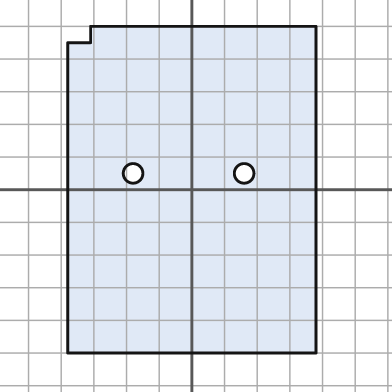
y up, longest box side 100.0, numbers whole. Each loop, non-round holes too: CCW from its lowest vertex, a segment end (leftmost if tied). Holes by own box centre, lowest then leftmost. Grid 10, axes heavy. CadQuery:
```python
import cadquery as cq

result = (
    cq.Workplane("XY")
    .moveTo(-38.0, -50.0)
    .lineTo(38.0, -50.0)
    .lineTo(38.0, 50.0)
    .lineTo(-31.0, 50.0)
    .lineTo(-31.0, 45.0)
    .lineTo(-38.0, 45.0)
    .close()
    .moveTo(-18.0, 5.0)
    .circle(3.0)
    .moveTo(16.0, 5.0)
    .circle(3.0)
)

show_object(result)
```